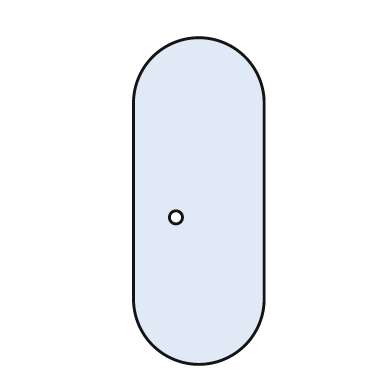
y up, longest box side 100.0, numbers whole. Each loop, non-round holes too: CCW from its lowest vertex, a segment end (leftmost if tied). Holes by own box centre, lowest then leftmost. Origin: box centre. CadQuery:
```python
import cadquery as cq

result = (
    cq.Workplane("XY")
    .moveTo(-20.0, -30.0)
    .threePointArc((0.0, -50.0), (20.0, -30.0))
    .lineTo(20.0, 30.0)
    .threePointArc((0.0, 50.0), (-20.0, 30.0))
    .close()
    .moveTo(-7.0, -5.0)
    .circle(2.0)
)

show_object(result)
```